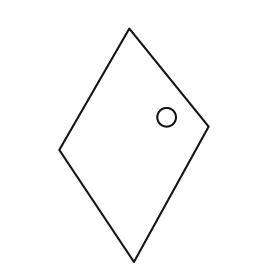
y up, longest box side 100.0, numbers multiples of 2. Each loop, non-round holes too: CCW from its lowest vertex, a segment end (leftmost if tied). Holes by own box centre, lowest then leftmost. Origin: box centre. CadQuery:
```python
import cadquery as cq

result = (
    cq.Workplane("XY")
    .moveTo(0.0, -50.0)
    .lineTo(32.0, 8.0)
    .lineTo(-2.0, 50.0)
    .lineTo(-32.0, -2.0)
    .close()
    .moveTo(14.0, 12.0)
    .circle(4.0)
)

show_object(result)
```